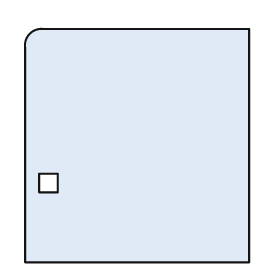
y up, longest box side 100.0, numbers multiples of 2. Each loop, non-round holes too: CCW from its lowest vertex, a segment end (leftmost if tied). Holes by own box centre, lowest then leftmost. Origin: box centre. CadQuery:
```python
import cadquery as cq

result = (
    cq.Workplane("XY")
    .moveTo(-48.0, -50.0)
    .lineTo(48.0, -50.0)
    .lineTo(48.0, 50.0)
    .lineTo(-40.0, 50.0)
    .threePointArc((-46.0, 48.0), (-48.0, 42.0))
    .close()
    .moveTo(-42.0, -20.0)
    .lineTo(-34.0, -20.0)
    .lineTo(-34.0, -12.0)
    .lineTo(-42.0, -12.0)
    .close()
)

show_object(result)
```